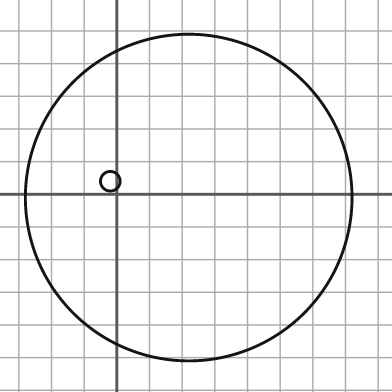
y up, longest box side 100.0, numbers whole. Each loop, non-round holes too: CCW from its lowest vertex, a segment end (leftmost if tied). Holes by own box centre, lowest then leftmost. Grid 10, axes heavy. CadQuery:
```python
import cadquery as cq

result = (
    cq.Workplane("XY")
    .moveTo(22.0, -1.0)
    .circle(50.0)
    .moveTo(-2.0, 4.0)
    .circle(3.0)
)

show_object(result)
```